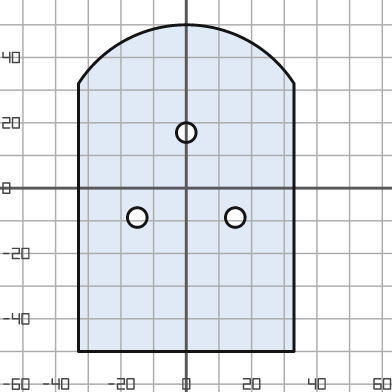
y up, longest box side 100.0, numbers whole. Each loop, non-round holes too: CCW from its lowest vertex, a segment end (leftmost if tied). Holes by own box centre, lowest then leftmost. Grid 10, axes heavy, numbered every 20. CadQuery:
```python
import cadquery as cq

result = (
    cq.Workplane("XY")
    .moveTo(-33.0, -50.0)
    .lineTo(33.0, -50.0)
    .lineTo(33.0, 32.0)
    .threePointArc((0.0, 50.0), (-33.0, 32.0))
    .close()
    .moveTo(-15.0, -9.0)
    .circle(3.0)
    .moveTo(15.0, -9.0)
    .circle(3.0)
    .moveTo(0.0, 17.0)
    .circle(3.0)
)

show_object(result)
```